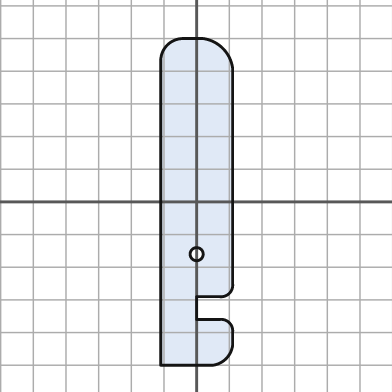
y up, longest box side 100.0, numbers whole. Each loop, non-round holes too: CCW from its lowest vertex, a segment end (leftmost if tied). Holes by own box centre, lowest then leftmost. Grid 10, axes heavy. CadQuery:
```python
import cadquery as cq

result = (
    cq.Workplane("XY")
    .moveTo(-11.0, -50.0)
    .lineTo(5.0, -50.0)
    .threePointArc((9.0, -48.0), (11.0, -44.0))
    .lineTo(11.0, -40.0)
    .threePointArc((10.0, -37.0), (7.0, -36.0))
    .lineTo(0.0, -36.0)
    .lineTo(0.0, -29.0)
    .lineTo(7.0, -29.0)
    .threePointArc((10.0, -28.0), (11.0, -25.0))
    .lineTo(11.0, 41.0)
    .threePointArc((8.0, 47.0), (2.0, 50.0))
    .lineTo(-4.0, 50.0)
    .threePointArc((-9.0, 48.0), (-11.0, 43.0))
    .close()
    .moveTo(0.0, -16.0)
    .circle(2.0)
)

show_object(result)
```